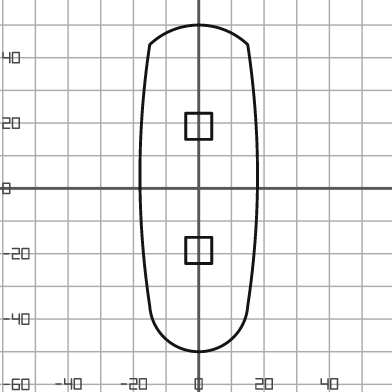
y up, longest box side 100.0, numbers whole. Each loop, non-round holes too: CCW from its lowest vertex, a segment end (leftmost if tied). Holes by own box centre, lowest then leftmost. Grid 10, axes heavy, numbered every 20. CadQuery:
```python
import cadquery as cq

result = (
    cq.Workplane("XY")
    .moveTo(-15.0, -36.0)
    .threePointArc((0.0, -50.0), (15.0, -36.0))
    .threePointArc((18.0, 4.0), (15.0, 44.0))
    .threePointArc((0.0, 50.0), (-15.0, 44.0))
    .threePointArc((-18.0, 4.0), (-15.0, -36.0))
    .close()
    .moveTo(-4.0, -23.0)
    .lineTo(4.0, -23.0)
    .lineTo(4.0, -15.0)
    .lineTo(-4.0, -15.0)
    .close()
    .moveTo(-4.0, 15.0)
    .lineTo(4.0, 15.0)
    .lineTo(4.0, 23.0)
    .lineTo(-4.0, 23.0)
    .close()
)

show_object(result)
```